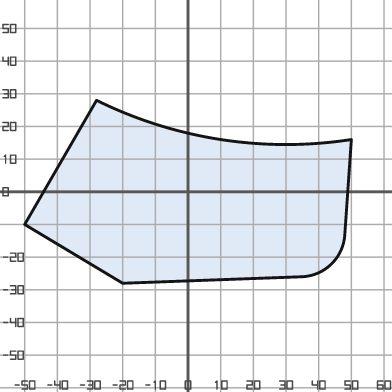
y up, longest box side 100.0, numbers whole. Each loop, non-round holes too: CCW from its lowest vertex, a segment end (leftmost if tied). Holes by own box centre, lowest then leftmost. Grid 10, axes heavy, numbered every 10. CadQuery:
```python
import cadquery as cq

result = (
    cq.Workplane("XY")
    .moveTo(-20.0, -28.0)
    .lineTo(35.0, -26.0)
    .threePointArc((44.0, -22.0), (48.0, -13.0))
    .lineTo(50.0, 16.0)
    .threePointArc((10.0, 16.0), (-28.0, 28.0))
    .lineTo(-50.0, -10.0)
    .close()
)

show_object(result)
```